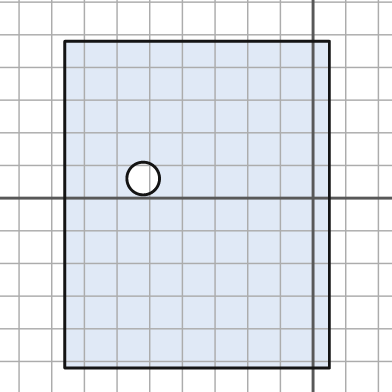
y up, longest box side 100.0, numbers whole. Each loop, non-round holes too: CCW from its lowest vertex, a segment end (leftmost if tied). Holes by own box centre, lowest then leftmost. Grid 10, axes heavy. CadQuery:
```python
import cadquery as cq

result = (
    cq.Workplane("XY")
    .moveTo(-76.0, -52.0)
    .lineTo(5.0, -52.0)
    .lineTo(5.0, 48.0)
    .lineTo(-76.0, 48.0)
    .close()
    .moveTo(-52.0, 6.0)
    .circle(5.0)
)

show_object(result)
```